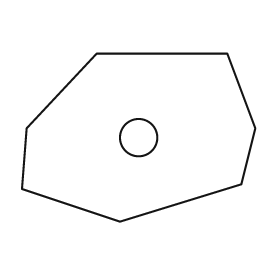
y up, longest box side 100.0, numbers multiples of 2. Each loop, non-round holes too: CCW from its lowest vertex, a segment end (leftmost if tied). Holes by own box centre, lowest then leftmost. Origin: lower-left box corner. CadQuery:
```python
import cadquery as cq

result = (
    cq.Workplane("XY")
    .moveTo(42.0, 0.0)
    .lineTo(94.0, 16.0)
    .lineTo(100.0, 40.0)
    .lineTo(88.0, 72.0)
    .lineTo(32.0, 72.0)
    .lineTo(2.0, 40.0)
    .lineTo(0.0, 14.0)
    .close()
    .moveTo(50.0, 36.0)
    .circle(8.0)
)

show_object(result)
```